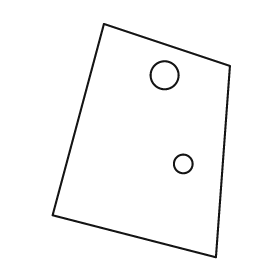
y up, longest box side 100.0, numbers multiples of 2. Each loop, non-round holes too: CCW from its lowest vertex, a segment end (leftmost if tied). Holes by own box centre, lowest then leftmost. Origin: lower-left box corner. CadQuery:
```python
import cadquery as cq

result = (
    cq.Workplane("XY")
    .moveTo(70.0, 0.0)
    .lineTo(76.0, 82.0)
    .lineTo(22.0, 100.0)
    .lineTo(0.0, 18.0)
    .close()
    .moveTo(56.0, 40.0)
    .circle(4.0)
    .moveTo(48.0, 78.0)
    .circle(6.0)
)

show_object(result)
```